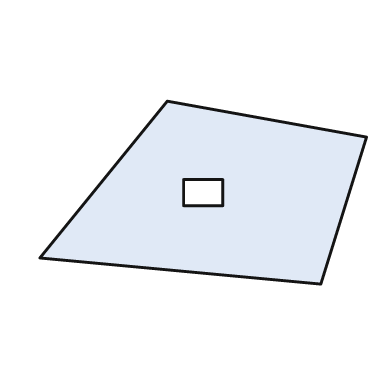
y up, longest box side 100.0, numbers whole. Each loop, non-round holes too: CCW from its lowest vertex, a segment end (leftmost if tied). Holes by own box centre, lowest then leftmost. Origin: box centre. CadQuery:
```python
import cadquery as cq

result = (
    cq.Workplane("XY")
    .moveTo(36.0, -28.0)
    .lineTo(50.0, 17.0)
    .lineTo(-11.0, 28.0)
    .lineTo(-50.0, -20.0)
    .close()
    .moveTo(-6.0, -4.0)
    .lineTo(6.0, -4.0)
    .lineTo(6.0, 4.0)
    .lineTo(-6.0, 4.0)
    .close()
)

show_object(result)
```